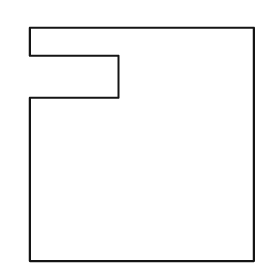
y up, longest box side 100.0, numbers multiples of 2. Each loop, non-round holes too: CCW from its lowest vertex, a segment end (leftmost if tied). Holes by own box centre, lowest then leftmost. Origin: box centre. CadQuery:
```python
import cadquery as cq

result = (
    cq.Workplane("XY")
    .moveTo(-48.0, -50.0)
    .lineTo(48.0, -50.0)
    .lineTo(48.0, 50.0)
    .lineTo(-48.0, 50.0)
    .lineTo(-48.0, 38.0)
    .lineTo(-10.0, 38.0)
    .lineTo(-10.0, 20.0)
    .lineTo(-48.0, 20.0)
    .close()
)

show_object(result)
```